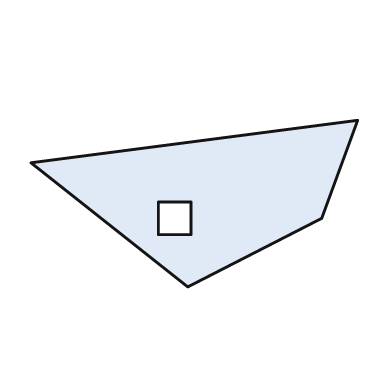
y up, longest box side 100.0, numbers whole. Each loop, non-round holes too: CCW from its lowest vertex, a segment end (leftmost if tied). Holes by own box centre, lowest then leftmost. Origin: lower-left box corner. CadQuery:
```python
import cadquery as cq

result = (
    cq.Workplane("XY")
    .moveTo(48.0, 0.0)
    .lineTo(89.0, 21.0)
    .lineTo(100.0, 51.0)
    .lineTo(0.0, 38.0)
    .close()
    .moveTo(39.0, 16.0)
    .lineTo(49.0, 16.0)
    .lineTo(49.0, 26.0)
    .lineTo(39.0, 26.0)
    .close()
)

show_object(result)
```